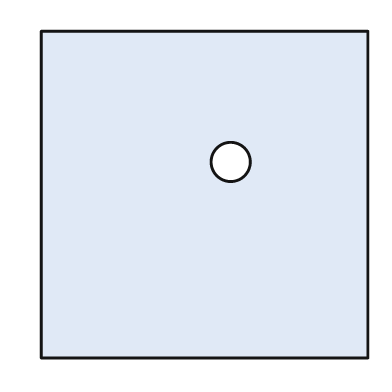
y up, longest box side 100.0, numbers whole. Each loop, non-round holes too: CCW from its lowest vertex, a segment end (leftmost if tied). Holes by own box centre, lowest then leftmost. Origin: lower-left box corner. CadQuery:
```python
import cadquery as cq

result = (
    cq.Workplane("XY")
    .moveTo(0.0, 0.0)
    .lineTo(100.0, 0.0)
    .lineTo(100.0, 100.0)
    .lineTo(0.0, 100.0)
    .close()
    .moveTo(58.0, 60.0)
    .circle(6.0)
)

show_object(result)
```